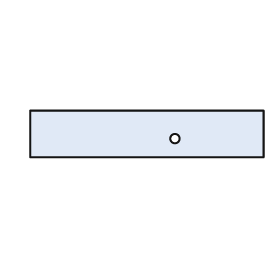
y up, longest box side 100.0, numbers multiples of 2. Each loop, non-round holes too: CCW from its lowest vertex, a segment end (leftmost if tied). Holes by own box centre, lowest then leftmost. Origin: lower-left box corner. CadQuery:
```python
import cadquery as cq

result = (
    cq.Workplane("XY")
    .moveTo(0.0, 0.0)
    .lineTo(100.0, 0.0)
    .lineTo(100.0, 20.0)
    .lineTo(0.0, 20.0)
    .close()
    .moveTo(62.0, 8.0)
    .circle(2.0)
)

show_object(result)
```